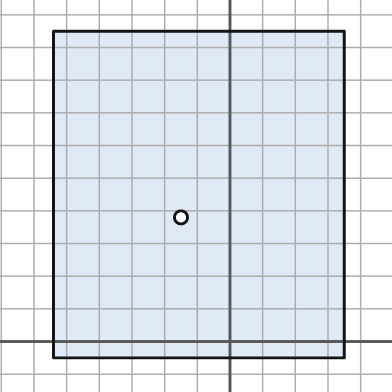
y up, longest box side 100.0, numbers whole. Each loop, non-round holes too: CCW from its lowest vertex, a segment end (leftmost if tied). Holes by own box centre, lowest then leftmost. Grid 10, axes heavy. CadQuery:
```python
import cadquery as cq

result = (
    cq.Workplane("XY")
    .moveTo(-54.0, -5.0)
    .lineTo(35.0, -5.0)
    .lineTo(35.0, 95.0)
    .lineTo(-54.0, 95.0)
    .close()
    .moveTo(-15.0, 38.0)
    .circle(2.0)
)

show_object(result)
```